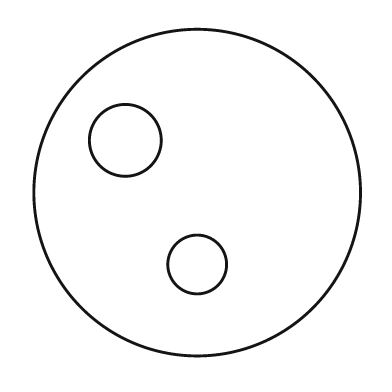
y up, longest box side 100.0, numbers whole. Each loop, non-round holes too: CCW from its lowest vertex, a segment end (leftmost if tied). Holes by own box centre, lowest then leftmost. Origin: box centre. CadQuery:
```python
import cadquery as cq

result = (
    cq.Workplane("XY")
    .moveTo(0.0, 0.0)
    .circle(50.0)
    .moveTo(0.0, -22.0)
    .circle(9.0)
    .moveTo(-22.0, 16.0)
    .circle(11.0)
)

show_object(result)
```